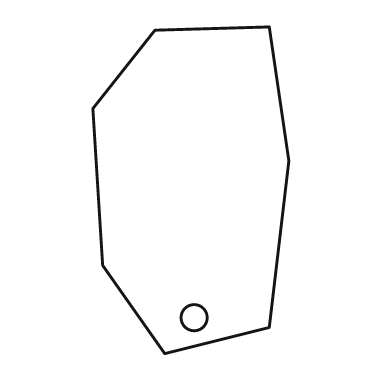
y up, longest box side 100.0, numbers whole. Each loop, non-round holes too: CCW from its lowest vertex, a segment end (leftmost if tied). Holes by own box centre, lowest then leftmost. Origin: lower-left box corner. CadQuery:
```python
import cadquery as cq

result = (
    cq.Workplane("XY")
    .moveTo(22.0, 0.0)
    .lineTo(54.0, 8.0)
    .lineTo(60.0, 59.0)
    .lineTo(54.0, 100.0)
    .lineTo(19.0, 99.0)
    .lineTo(0.0, 75.0)
    .lineTo(3.0, 27.0)
    .close()
    .moveTo(31.0, 11.0)
    .circle(4.0)
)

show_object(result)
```